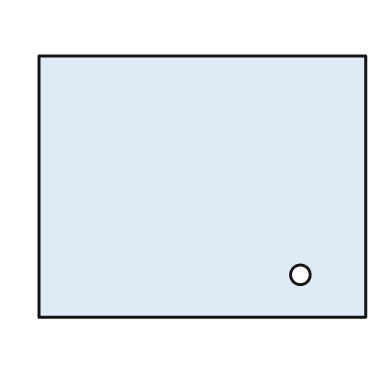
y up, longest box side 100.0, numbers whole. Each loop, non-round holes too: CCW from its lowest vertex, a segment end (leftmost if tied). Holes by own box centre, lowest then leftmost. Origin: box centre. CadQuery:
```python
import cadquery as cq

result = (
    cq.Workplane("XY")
    .moveTo(-50.0, -40.0)
    .lineTo(50.0, -40.0)
    .lineTo(50.0, 40.0)
    .lineTo(-50.0, 40.0)
    .close()
    .moveTo(30.0, -27.0)
    .circle(3.0)
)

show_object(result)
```